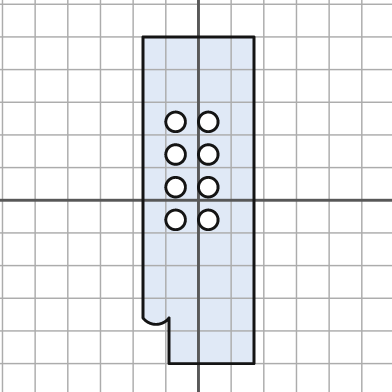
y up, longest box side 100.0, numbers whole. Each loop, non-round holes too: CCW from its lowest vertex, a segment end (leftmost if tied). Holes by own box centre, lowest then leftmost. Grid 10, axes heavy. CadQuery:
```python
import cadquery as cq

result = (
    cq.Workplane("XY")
    .moveTo(-9.0, -50.0)
    .lineTo(17.0, -50.0)
    .lineTo(17.0, 50.0)
    .lineTo(-17.0, 50.0)
    .lineTo(-17.0, -36.0)
    .threePointArc((-13.0, -38.0), (-9.0, -36.0))
    .close()
    .moveTo(-7.0, -6.0)
    .circle(3.0)
    .moveTo(3.0, -6.0)
    .circle(3.0)
    .moveTo(-7.0, 4.0)
    .circle(3.0)
    .moveTo(3.0, 4.0)
    .circle(3.0)
    .moveTo(-7.0, 14.0)
    .circle(3.0)
    .moveTo(3.0, 14.0)
    .circle(3.0)
    .moveTo(-7.0, 24.0)
    .circle(3.0)
    .moveTo(3.0, 24.0)
    .circle(3.0)
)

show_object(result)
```